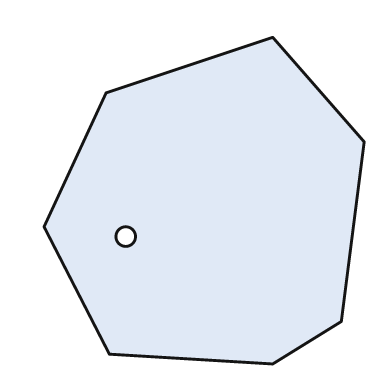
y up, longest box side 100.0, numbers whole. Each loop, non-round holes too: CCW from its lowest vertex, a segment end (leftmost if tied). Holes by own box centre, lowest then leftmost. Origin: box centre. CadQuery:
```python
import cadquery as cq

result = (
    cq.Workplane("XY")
    .moveTo(21.0, -50.0)
    .lineTo(42.0, -37.0)
    .lineTo(49.0, 18.0)
    .lineTo(21.0, 50.0)
    .lineTo(-30.0, 33.0)
    .lineTo(-49.0, -8.0)
    .lineTo(-29.0, -47.0)
    .close()
    .moveTo(-24.0, -11.0)
    .circle(3.0)
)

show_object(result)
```